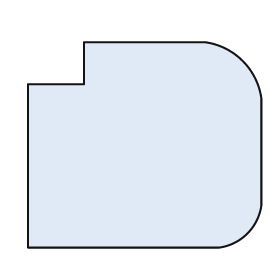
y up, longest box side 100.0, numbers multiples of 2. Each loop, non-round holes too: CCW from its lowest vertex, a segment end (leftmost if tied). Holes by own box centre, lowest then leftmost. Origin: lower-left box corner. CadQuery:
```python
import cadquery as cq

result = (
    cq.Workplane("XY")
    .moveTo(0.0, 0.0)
    .lineTo(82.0, 0.0)
    .threePointArc((94.0, 6.0), (100.0, 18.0))
    .lineTo(100.0, 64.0)
    .threePointArc((92.0, 80.0), (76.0, 88.0))
    .lineTo(24.0, 88.0)
    .lineTo(24.0, 70.0)
    .lineTo(0.0, 70.0)
    .close()
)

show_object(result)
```